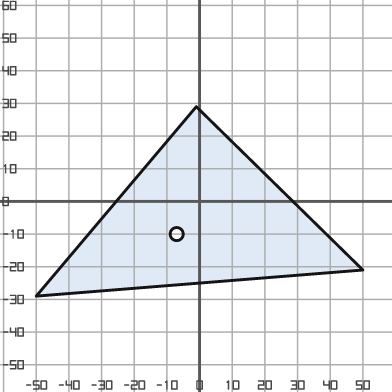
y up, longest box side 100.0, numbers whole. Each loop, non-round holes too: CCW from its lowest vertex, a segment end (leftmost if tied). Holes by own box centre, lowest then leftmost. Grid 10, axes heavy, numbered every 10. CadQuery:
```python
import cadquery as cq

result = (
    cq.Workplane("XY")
    .moveTo(-50.0, -29.0)
    .lineTo(50.0, -21.0)
    .lineTo(-1.0, 29.0)
    .close()
    .moveTo(-7.0, -10.0)
    .circle(2.0)
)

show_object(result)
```